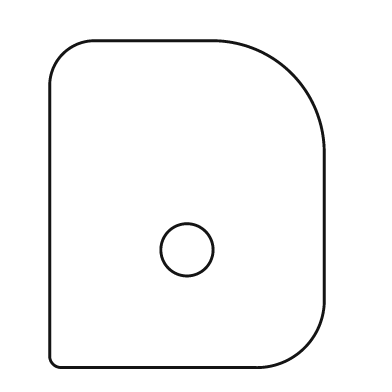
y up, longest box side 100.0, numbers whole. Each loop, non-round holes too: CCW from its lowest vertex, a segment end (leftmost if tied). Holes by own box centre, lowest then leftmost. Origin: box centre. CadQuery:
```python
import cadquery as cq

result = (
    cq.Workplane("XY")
    .moveTo(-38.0, -50.0)
    .lineTo(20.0, -50.0)
    .threePointArc((36.0, -44.0), (42.0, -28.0))
    .lineTo(42.0, 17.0)
    .threePointArc((32.0, 40.0), (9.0, 50.0))
    .lineTo(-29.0, 50.0)
    .threePointArc((-38.0, 46.0), (-42.0, 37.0))
    .lineTo(-42.0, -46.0)
    .threePointArc((-41.0, -49.0), (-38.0, -50.0))
    .close()
    .moveTo(0.0, -14.0)
    .circle(8.0)
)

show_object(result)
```